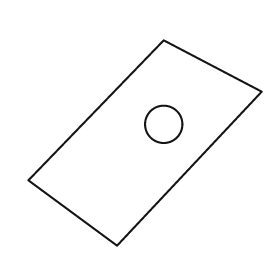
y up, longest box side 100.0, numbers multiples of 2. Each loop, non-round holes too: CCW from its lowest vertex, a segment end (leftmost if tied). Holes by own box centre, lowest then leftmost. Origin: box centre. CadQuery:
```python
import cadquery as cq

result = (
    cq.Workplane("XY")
    .moveTo(-12.0, -44.0)
    .lineTo(50.0, 22.0)
    .lineTo(8.0, 44.0)
    .lineTo(-50.0, -16.0)
    .close()
    .moveTo(8.0, 8.0)
    .circle(8.0)
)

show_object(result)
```